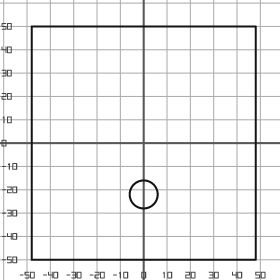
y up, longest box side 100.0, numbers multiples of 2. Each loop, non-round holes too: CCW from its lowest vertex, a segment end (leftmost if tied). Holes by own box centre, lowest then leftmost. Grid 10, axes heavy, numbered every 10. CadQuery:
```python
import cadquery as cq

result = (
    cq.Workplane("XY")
    .moveTo(-48.0, -50.0)
    .lineTo(48.0, -50.0)
    .lineTo(48.0, 50.0)
    .lineTo(-48.0, 50.0)
    .close()
    .moveTo(0.0, -22.0)
    .circle(6.0)
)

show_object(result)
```